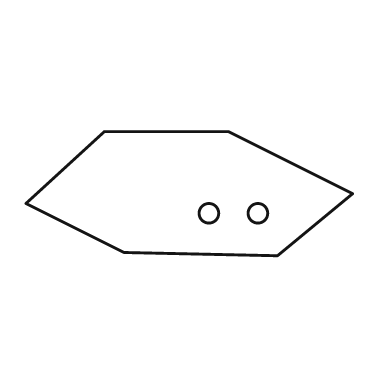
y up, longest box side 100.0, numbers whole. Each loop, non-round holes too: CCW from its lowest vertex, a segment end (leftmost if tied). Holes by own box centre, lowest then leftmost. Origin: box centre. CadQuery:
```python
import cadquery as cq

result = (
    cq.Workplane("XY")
    .moveTo(27.0, -19.0)
    .lineTo(50.0, 0.0)
    .lineTo(12.0, 19.0)
    .lineTo(-26.0, 19.0)
    .lineTo(-50.0, -3.0)
    .lineTo(-20.0, -18.0)
    .close()
    .moveTo(6.0, -6.0)
    .circle(3.0)
    .moveTo(21.0, -6.0)
    .circle(3.0)
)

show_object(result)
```